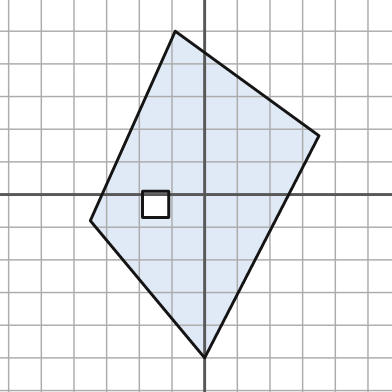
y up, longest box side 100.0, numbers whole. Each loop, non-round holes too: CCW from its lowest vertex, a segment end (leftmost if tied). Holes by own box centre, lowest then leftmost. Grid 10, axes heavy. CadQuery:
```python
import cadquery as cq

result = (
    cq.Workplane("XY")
    .moveTo(0.0, -50.0)
    .lineTo(35.0, 18.0)
    .lineTo(-9.0, 50.0)
    .lineTo(-35.0, -8.0)
    .close()
    .moveTo(-19.0, -7.0)
    .lineTo(-11.0, -7.0)
    .lineTo(-11.0, 1.0)
    .lineTo(-19.0, 1.0)
    .close()
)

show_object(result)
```